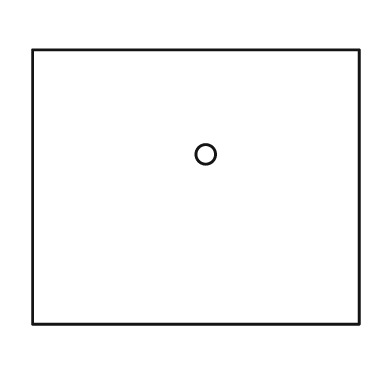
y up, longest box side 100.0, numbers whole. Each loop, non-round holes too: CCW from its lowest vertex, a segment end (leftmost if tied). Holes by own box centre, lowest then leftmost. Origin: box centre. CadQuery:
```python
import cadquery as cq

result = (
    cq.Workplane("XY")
    .moveTo(-50.0, -42.0)
    .lineTo(50.0, -42.0)
    .lineTo(50.0, 42.0)
    .lineTo(-50.0, 42.0)
    .close()
    .moveTo(3.0, 10.0)
    .circle(3.0)
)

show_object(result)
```